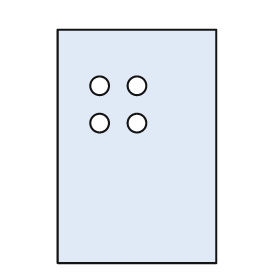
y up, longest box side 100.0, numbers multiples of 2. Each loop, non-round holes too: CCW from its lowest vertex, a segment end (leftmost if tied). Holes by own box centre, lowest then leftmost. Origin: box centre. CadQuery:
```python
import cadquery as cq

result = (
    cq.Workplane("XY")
    .moveTo(-34.0, -50.0)
    .lineTo(34.0, -50.0)
    .lineTo(34.0, 50.0)
    .lineTo(-34.0, 50.0)
    .close()
    .moveTo(-16.0, 10.0)
    .circle(4.0)
    .moveTo(0.0, 10.0)
    .circle(4.0)
    .moveTo(-16.0, 26.0)
    .circle(4.0)
    .moveTo(0.0, 26.0)
    .circle(4.0)
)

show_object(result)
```